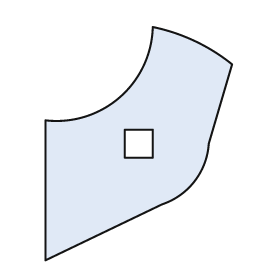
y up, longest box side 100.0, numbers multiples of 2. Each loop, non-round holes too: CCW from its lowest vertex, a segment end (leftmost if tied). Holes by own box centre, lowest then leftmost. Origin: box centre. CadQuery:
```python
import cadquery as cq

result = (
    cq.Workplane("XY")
    .moveTo(-40.0, -50.0)
    .lineTo(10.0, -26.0)
    .threePointArc((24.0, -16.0), (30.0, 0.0))
    .lineTo(40.0, 34.0)
    .threePointArc((24.0, 44.0), (6.0, 50.0))
    .threePointArc((-8.0, 20.0), (-40.0, 10.0))
    .close()
    .moveTo(-6.0, -6.0)
    .lineTo(6.0, -6.0)
    .lineTo(6.0, 6.0)
    .lineTo(-6.0, 6.0)
    .close()
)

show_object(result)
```